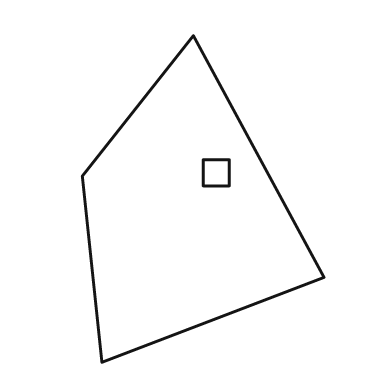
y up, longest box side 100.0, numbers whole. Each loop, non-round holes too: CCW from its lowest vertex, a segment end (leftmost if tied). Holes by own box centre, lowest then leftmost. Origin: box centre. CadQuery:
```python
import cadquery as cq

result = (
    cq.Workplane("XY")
    .moveTo(-31.0, -50.0)
    .lineTo(37.0, -24.0)
    .lineTo(-3.0, 50.0)
    .lineTo(-37.0, 7.0)
    .close()
    .moveTo(0.0, 4.0)
    .lineTo(8.0, 4.0)
    .lineTo(8.0, 12.0)
    .lineTo(0.0, 12.0)
    .close()
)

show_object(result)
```